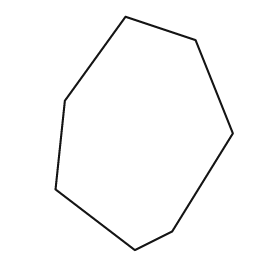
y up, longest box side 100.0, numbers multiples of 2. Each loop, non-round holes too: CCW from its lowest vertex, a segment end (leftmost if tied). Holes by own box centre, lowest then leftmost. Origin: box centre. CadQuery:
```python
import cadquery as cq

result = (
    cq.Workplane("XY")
    .moveTo(-4.0, -50.0)
    .lineTo(12.0, -42.0)
    .lineTo(38.0, 0.0)
    .lineTo(22.0, 40.0)
    .lineTo(-8.0, 50.0)
    .lineTo(-34.0, 14.0)
    .lineTo(-38.0, -24.0)
    .close()
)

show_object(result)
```